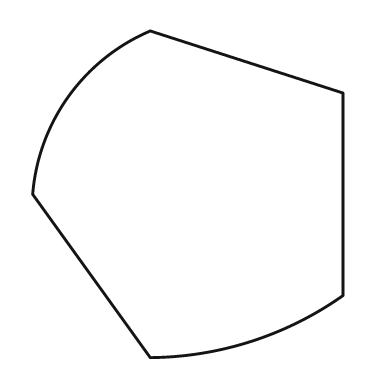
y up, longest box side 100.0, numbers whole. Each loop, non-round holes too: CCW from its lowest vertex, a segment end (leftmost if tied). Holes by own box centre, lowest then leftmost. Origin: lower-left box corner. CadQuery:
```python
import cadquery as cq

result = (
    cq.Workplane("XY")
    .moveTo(36.0, 0.0)
    .threePointArc((67.0, 5.0), (95.0, 19.0))
    .lineTo(95.0, 81.0)
    .lineTo(36.0, 100.0)
    .threePointArc((11.0, 80.0), (0.0, 50.0))
    .close()
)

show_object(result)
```